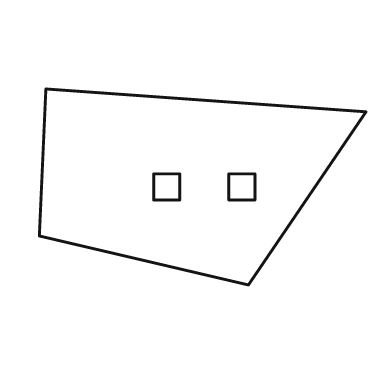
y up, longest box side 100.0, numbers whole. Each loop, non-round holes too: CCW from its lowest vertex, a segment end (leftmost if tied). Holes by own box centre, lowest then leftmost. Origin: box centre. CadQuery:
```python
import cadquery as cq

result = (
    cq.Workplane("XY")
    .moveTo(14.0, -30.0)
    .lineTo(50.0, 23.0)
    .lineTo(-48.0, 30.0)
    .lineTo(-50.0, -15.0)
    .close()
    .moveTo(-15.0, -4.0)
    .lineTo(-7.0, -4.0)
    .lineTo(-7.0, 4.0)
    .lineTo(-15.0, 4.0)
    .close()
    .moveTo(8.0, -4.0)
    .lineTo(16.0, -4.0)
    .lineTo(16.0, 4.0)
    .lineTo(8.0, 4.0)
    .close()
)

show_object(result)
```